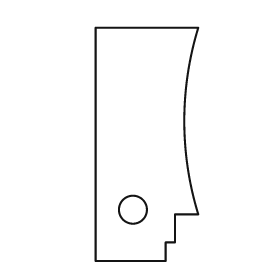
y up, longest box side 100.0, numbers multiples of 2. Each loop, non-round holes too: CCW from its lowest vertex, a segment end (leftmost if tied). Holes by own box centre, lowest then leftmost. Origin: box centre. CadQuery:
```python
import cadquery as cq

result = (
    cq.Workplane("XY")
    .moveTo(-22.0, -50.0)
    .lineTo(8.0, -50.0)
    .lineTo(8.0, -42.0)
    .lineTo(12.0, -42.0)
    .lineTo(12.0, -30.0)
    .lineTo(22.0, -30.0)
    .threePointArc((16.0, 10.0), (22.0, 50.0))
    .lineTo(-22.0, 50.0)
    .close()
    .moveTo(-6.0, -28.0)
    .circle(6.0)
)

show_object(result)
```